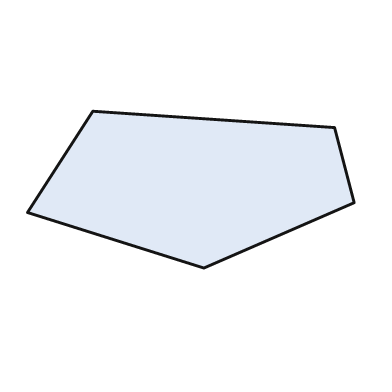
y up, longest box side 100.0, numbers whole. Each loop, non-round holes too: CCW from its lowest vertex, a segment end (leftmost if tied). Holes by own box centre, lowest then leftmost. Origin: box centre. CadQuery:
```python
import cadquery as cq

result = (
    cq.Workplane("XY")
    .moveTo(4.0, -24.0)
    .lineTo(50.0, -4.0)
    .lineTo(44.0, 19.0)
    .lineTo(-30.0, 24.0)
    .lineTo(-50.0, -7.0)
    .close()
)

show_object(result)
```